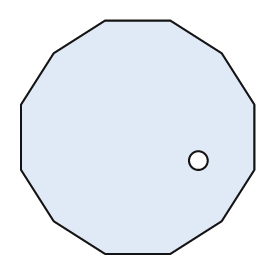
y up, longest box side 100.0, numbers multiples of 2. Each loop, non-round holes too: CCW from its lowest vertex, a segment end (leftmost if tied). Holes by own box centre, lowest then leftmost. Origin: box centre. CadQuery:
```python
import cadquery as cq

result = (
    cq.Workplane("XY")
    .moveTo(-14.0, -50.0)
    .lineTo(14.0, -50.0)
    .lineTo(36.0, -36.0)
    .lineTo(50.0, -14.0)
    .lineTo(50.0, 14.0)
    .lineTo(36.0, 36.0)
    .lineTo(14.0, 50.0)
    .lineTo(-14.0, 50.0)
    .lineTo(-36.0, 36.0)
    .lineTo(-50.0, 14.0)
    .lineTo(-50.0, -14.0)
    .lineTo(-36.0, -36.0)
    .close()
    .moveTo(26.0, -10.0)
    .circle(4.0)
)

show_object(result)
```